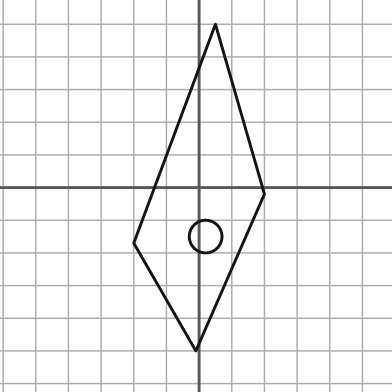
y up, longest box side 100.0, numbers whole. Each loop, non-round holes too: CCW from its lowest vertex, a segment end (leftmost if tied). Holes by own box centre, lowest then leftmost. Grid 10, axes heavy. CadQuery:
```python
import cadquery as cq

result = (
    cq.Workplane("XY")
    .moveTo(-1.0, -50.0)
    .lineTo(20.0, -2.0)
    .lineTo(5.0, 50.0)
    .lineTo(-20.0, -17.0)
    .close()
    .moveTo(2.0, -15.0)
    .circle(5.0)
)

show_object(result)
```